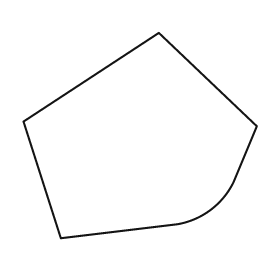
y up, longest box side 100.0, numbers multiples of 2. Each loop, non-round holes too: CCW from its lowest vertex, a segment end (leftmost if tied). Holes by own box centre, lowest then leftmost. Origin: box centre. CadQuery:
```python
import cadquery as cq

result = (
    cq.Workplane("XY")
    .moveTo(-34.0, -44.0)
    .lineTo(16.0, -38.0)
    .threePointArc((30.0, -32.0), (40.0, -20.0))
    .lineTo(50.0, 4.0)
    .lineTo(8.0, 44.0)
    .lineTo(-50.0, 6.0)
    .close()
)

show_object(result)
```